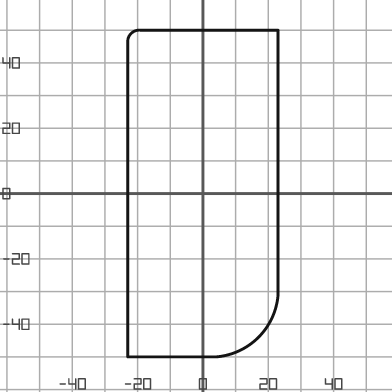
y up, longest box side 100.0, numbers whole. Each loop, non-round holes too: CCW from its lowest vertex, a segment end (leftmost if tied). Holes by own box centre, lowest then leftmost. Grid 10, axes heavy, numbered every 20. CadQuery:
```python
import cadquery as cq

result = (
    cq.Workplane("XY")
    .moveTo(-23.0, -50.0)
    .lineTo(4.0, -50.0)
    .threePointArc((17.0, -44.0), (23.0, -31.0))
    .lineTo(23.0, 50.0)
    .lineTo(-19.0, 50.0)
    .threePointArc((-22.0, 49.0), (-23.0, 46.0))
    .close()
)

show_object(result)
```